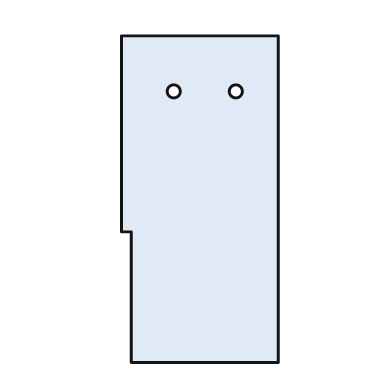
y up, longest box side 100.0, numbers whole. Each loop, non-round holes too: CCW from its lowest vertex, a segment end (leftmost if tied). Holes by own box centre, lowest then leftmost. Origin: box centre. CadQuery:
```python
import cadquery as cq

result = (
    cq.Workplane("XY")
    .moveTo(-21.0, -50.0)
    .lineTo(24.0, -50.0)
    .lineTo(24.0, 50.0)
    .lineTo(-24.0, 50.0)
    .lineTo(-24.0, -10.0)
    .lineTo(-21.0, -10.0)
    .close()
    .moveTo(-8.0, 33.0)
    .circle(2.0)
    .moveTo(11.0, 33.0)
    .circle(2.0)
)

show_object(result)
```